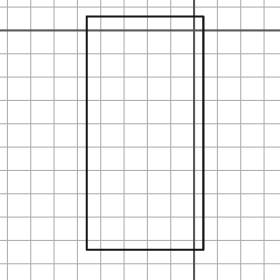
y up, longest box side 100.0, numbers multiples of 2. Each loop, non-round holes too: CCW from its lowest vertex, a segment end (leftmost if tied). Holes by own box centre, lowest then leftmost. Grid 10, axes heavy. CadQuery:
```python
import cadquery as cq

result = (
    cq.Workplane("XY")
    .moveTo(-46.0, -94.0)
    .lineTo(4.0, -94.0)
    .lineTo(4.0, 6.0)
    .lineTo(-46.0, 6.0)
    .close()
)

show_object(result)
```